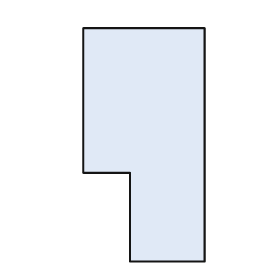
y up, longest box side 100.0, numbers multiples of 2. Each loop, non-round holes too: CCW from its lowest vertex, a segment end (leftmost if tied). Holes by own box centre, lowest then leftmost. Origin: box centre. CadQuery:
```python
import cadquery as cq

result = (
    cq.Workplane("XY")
    .moveTo(-6.0, -50.0)
    .lineTo(26.0, -50.0)
    .lineTo(26.0, 50.0)
    .lineTo(-26.0, 50.0)
    .lineTo(-26.0, -12.0)
    .lineTo(-6.0, -12.0)
    .close()
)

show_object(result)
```